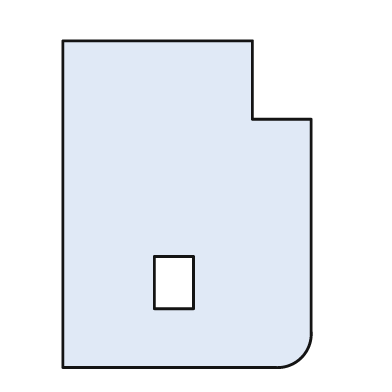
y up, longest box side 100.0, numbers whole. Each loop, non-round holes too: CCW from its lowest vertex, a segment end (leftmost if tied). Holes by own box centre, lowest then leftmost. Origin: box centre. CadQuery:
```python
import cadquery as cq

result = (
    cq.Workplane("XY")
    .moveTo(-38.0, -50.0)
    .lineTo(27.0, -50.0)
    .threePointArc((35.0, -47.0), (38.0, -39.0))
    .lineTo(38.0, 26.0)
    .lineTo(20.0, 26.0)
    .lineTo(20.0, 50.0)
    .lineTo(-38.0, 50.0)
    .close()
    .moveTo(-10.0, -32.0)
    .lineTo(2.0, -32.0)
    .lineTo(2.0, -16.0)
    .lineTo(-10.0, -16.0)
    .close()
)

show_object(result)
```